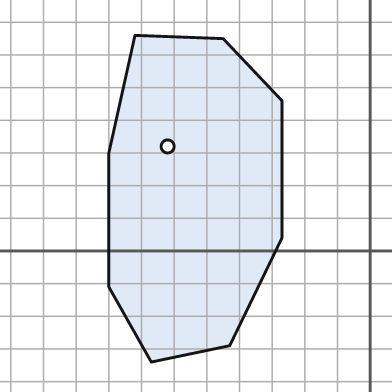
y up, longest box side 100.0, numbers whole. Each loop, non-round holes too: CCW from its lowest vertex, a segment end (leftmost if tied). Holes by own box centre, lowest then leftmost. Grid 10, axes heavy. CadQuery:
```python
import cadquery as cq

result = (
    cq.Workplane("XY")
    .moveTo(-67.0, -34.0)
    .lineTo(-43.0, -29.0)
    .lineTo(-27.0, 4.0)
    .lineTo(-27.0, 46.0)
    .lineTo(-45.0, 65.0)
    .lineTo(-72.0, 66.0)
    .lineTo(-80.0, 30.0)
    .lineTo(-80.0, -11.0)
    .close()
    .moveTo(-62.0, 32.0)
    .circle(2.0)
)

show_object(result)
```